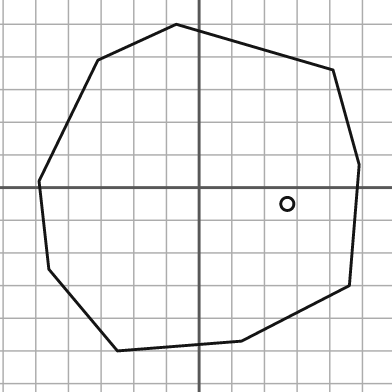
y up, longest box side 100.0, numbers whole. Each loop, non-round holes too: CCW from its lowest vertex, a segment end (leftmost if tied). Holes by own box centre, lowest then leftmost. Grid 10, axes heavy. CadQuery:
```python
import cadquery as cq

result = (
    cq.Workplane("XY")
    .moveTo(-25.0, -50.0)
    .lineTo(13.0, -47.0)
    .lineTo(46.0, -30.0)
    .lineTo(49.0, 7.0)
    .lineTo(41.0, 36.0)
    .lineTo(-7.0, 50.0)
    .lineTo(-31.0, 39.0)
    .lineTo(-49.0, 2.0)
    .lineTo(-46.0, -25.0)
    .close()
    .moveTo(27.0, -5.0)
    .circle(2.0)
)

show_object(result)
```